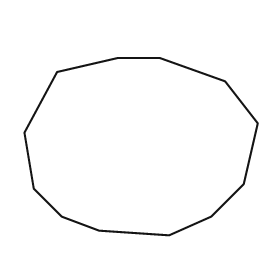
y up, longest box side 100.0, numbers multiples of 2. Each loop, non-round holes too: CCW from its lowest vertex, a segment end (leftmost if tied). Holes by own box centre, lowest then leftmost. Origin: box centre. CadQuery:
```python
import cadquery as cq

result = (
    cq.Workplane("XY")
    .moveTo(12.0, -38.0)
    .lineTo(30.0, -30.0)
    .lineTo(44.0, -16.0)
    .lineTo(50.0, 10.0)
    .lineTo(36.0, 28.0)
    .lineTo(8.0, 38.0)
    .lineTo(-10.0, 38.0)
    .lineTo(-36.0, 32.0)
    .lineTo(-50.0, 6.0)
    .lineTo(-46.0, -18.0)
    .lineTo(-34.0, -30.0)
    .lineTo(-18.0, -36.0)
    .close()
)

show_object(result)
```